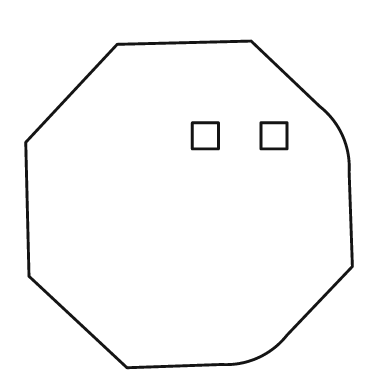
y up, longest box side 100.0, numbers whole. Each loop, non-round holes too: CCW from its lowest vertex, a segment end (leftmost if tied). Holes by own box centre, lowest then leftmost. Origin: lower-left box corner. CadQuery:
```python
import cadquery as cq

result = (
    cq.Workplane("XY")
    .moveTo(31.0, 0.0)
    .lineTo(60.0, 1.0)
    .threePointArc((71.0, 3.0), (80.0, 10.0))
    .lineTo(100.0, 31.0)
    .lineTo(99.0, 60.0)
    .threePointArc((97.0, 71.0), (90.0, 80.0))
    .lineTo(69.0, 100.0)
    .lineTo(28.0, 99.0)
    .lineTo(0.0, 69.0)
    .lineTo(1.0, 28.0)
    .close()
    .moveTo(51.0, 67.0)
    .lineTo(59.0, 67.0)
    .lineTo(59.0, 75.0)
    .lineTo(51.0, 75.0)
    .close()
    .moveTo(72.0, 67.0)
    .lineTo(80.0, 67.0)
    .lineTo(80.0, 75.0)
    .lineTo(72.0, 75.0)
    .close()
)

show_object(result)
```